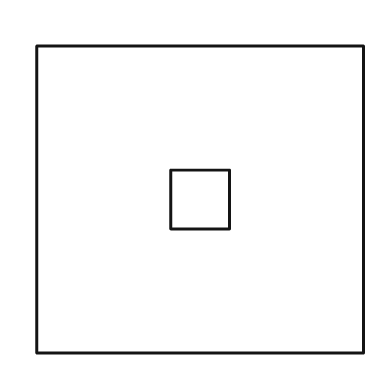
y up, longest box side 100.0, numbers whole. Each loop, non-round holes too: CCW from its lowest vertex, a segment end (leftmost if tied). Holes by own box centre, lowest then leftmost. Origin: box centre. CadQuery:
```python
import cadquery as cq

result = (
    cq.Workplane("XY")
    .moveTo(-50.0, -47.0)
    .lineTo(50.0, -47.0)
    .lineTo(50.0, 47.0)
    .lineTo(-50.0, 47.0)
    .close()
    .moveTo(-9.0, -9.0)
    .lineTo(9.0, -9.0)
    .lineTo(9.0, 9.0)
    .lineTo(-9.0, 9.0)
    .close()
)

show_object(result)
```